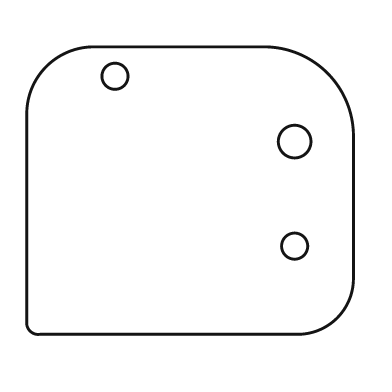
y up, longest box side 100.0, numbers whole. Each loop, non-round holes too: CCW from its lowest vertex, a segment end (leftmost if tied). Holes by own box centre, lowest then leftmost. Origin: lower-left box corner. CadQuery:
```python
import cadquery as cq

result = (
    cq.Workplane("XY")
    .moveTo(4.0, 0.0)
    .lineTo(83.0, 0.0)
    .threePointArc((95.0, 5.0), (100.0, 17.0))
    .lineTo(100.0, 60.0)
    .threePointArc((92.0, 80.0), (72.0, 88.0))
    .lineTo(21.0, 88.0)
    .threePointArc((6.0, 82.0), (0.0, 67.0))
    .lineTo(0.0, 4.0)
    .threePointArc((1.0, 1.0), (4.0, 0.0))
    .close()
    .moveTo(82.0, 27.0)
    .circle(4.0)
    .moveTo(82.0, 59.0)
    .circle(5.0)
    .moveTo(27.0, 79.0)
    .circle(4.0)
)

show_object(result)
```